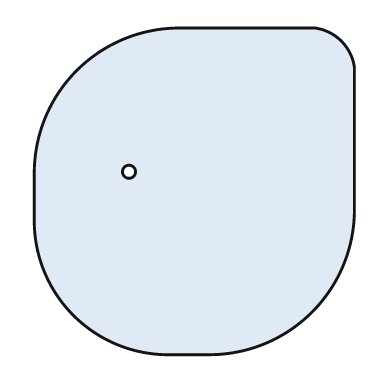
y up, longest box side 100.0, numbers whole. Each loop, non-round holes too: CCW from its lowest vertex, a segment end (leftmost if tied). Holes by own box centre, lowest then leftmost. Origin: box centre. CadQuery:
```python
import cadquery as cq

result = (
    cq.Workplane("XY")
    .moveTo(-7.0, -50.0)
    .lineTo(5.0, -50.0)
    .threePointArc((36.0, -37.0), (49.0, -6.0))
    .lineTo(49.0, 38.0)
    .threePointArc((45.0, 46.0), (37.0, 50.0))
    .lineTo(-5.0, 50.0)
    .threePointArc((-36.0, 37.0), (-49.0, 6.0))
    .lineTo(-49.0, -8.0)
    .threePointArc((-37.0, -38.0), (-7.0, -50.0))
    .close()
    .moveTo(-20.0, 6.0)
    .circle(2.0)
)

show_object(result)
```